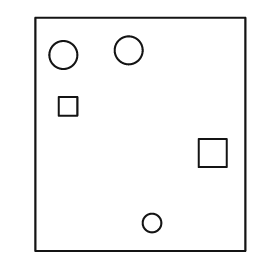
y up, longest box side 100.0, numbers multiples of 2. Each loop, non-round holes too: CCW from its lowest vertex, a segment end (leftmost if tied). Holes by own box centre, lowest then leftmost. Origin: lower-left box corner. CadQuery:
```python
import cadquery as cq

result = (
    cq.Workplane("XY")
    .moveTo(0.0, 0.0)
    .lineTo(90.0, 0.0)
    .lineTo(90.0, 100.0)
    .lineTo(0.0, 100.0)
    .close()
    .moveTo(50.0, 12.0)
    .circle(4.0)
    .moveTo(70.0, 36.0)
    .lineTo(82.0, 36.0)
    .lineTo(82.0, 48.0)
    .lineTo(70.0, 48.0)
    .close()
    .moveTo(10.0, 58.0)
    .lineTo(18.0, 58.0)
    .lineTo(18.0, 66.0)
    .lineTo(10.0, 66.0)
    .close()
    .moveTo(12.0, 84.0)
    .circle(6.0)
    .moveTo(40.0, 86.0)
    .circle(6.0)
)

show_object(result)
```